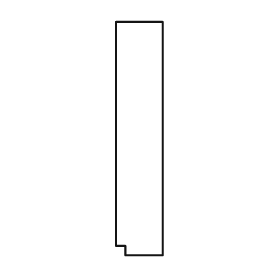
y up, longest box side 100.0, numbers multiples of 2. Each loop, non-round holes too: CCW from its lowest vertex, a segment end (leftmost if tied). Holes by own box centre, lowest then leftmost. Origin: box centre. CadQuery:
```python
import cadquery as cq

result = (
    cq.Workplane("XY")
    .moveTo(-6.0, -50.0)
    .lineTo(10.0, -50.0)
    .lineTo(10.0, 50.0)
    .lineTo(-10.0, 50.0)
    .lineTo(-10.0, -46.0)
    .lineTo(-6.0, -46.0)
    .close()
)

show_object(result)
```